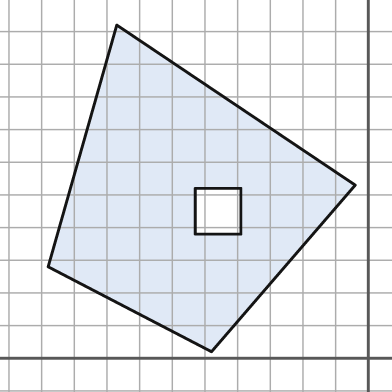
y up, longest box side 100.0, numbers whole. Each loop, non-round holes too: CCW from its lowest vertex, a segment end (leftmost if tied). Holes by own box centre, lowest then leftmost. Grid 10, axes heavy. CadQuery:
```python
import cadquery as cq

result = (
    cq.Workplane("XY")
    .moveTo(-48.0, 2.0)
    .lineTo(-4.0, 53.0)
    .lineTo(-77.0, 102.0)
    .lineTo(-98.0, 28.0)
    .close()
    .moveTo(-53.0, 38.0)
    .lineTo(-39.0, 38.0)
    .lineTo(-39.0, 52.0)
    .lineTo(-53.0, 52.0)
    .close()
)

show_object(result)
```